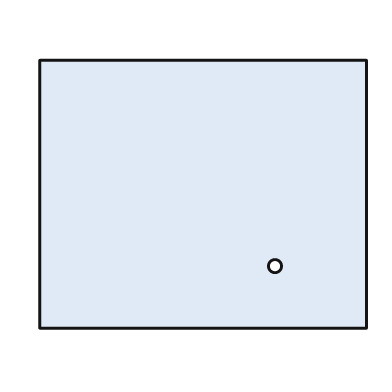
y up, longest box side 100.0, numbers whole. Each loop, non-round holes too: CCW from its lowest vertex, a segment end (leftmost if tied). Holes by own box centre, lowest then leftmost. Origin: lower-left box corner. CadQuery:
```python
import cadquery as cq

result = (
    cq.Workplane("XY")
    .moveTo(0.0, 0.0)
    .lineTo(100.0, 0.0)
    .lineTo(100.0, 82.0)
    .lineTo(0.0, 82.0)
    .close()
    .moveTo(72.0, 19.0)
    .circle(2.0)
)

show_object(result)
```